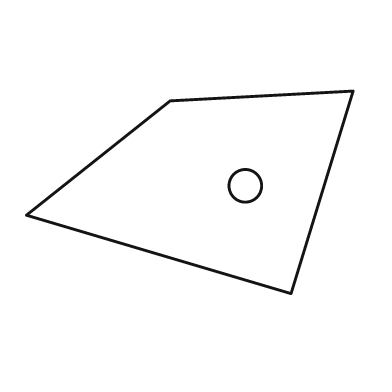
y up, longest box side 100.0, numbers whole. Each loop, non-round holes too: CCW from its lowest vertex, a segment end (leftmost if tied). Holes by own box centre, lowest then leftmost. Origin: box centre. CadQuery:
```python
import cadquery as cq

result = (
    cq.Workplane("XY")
    .moveTo(31.0, -31.0)
    .lineTo(50.0, 31.0)
    .lineTo(-6.0, 28.0)
    .lineTo(-50.0, -7.0)
    .close()
    .moveTo(17.0, 2.0)
    .circle(5.0)
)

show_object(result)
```